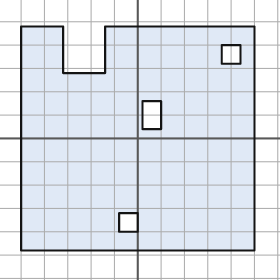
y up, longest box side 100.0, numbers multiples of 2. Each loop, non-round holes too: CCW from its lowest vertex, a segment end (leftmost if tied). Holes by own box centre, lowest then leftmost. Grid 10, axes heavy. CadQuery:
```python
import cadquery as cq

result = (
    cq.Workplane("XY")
    .moveTo(-50.0, -48.0)
    .lineTo(50.0, -48.0)
    .lineTo(50.0, 48.0)
    .lineTo(-14.0, 48.0)
    .lineTo(-14.0, 28.0)
    .lineTo(-32.0, 28.0)
    .lineTo(-32.0, 48.0)
    .lineTo(-50.0, 48.0)
    .close()
    .moveTo(-8.0, -40.0)
    .lineTo(0.0, -40.0)
    .lineTo(0.0, -32.0)
    .lineTo(-8.0, -32.0)
    .close()
    .moveTo(2.0, 4.0)
    .lineTo(10.0, 4.0)
    .lineTo(10.0, 16.0)
    .lineTo(2.0, 16.0)
    .close()
    .moveTo(36.0, 32.0)
    .lineTo(44.0, 32.0)
    .lineTo(44.0, 40.0)
    .lineTo(36.0, 40.0)
    .close()
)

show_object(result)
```